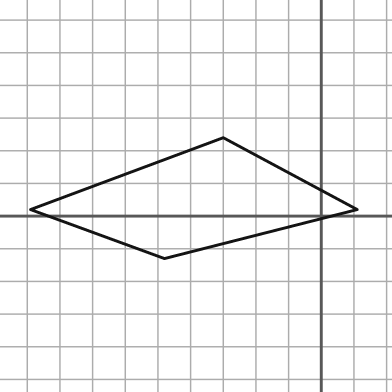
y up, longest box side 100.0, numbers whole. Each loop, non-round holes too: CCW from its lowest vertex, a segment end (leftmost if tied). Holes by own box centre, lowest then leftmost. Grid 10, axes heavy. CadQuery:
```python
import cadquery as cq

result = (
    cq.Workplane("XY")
    .moveTo(-48.0, -13.0)
    .lineTo(11.0, 2.0)
    .lineTo(-30.0, 24.0)
    .lineTo(-89.0, 2.0)
    .close()
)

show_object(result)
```